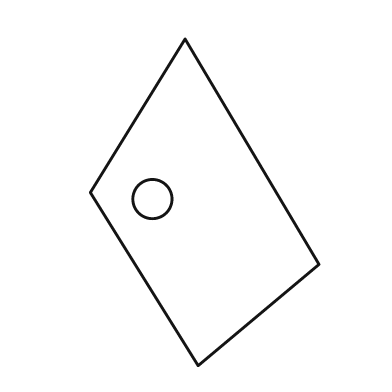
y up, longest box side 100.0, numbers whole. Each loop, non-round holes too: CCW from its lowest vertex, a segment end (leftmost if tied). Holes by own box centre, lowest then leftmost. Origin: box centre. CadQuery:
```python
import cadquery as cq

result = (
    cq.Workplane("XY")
    .moveTo(-2.0, -50.0)
    .lineTo(35.0, -19.0)
    .lineTo(-6.0, 50.0)
    .lineTo(-35.0, 3.0)
    .close()
    .moveTo(-16.0, 1.0)
    .circle(6.0)
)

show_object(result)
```